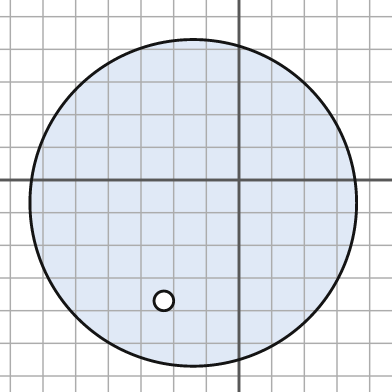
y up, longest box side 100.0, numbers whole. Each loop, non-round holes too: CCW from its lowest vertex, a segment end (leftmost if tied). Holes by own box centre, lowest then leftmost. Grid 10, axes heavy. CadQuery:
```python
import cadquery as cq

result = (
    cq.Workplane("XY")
    .moveTo(-14.0, -7.0)
    .circle(50.0)
    .moveTo(-23.0, -37.0)
    .circle(3.0)
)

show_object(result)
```